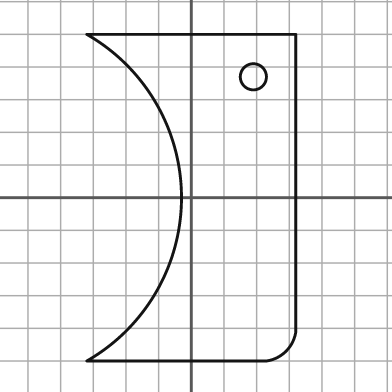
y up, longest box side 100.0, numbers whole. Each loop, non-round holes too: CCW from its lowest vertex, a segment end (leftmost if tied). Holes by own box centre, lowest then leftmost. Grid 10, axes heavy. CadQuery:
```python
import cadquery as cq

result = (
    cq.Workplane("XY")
    .moveTo(-32.0, -50.0)
    .lineTo(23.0, -50.0)
    .threePointArc((29.0, -47.0), (32.0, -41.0))
    .lineTo(32.0, 50.0)
    .lineTo(-32.0, 50.0)
    .threePointArc((-3.0, 0.0), (-32.0, -50.0))
    .close()
    .moveTo(19.0, 37.0)
    .circle(4.0)
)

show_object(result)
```